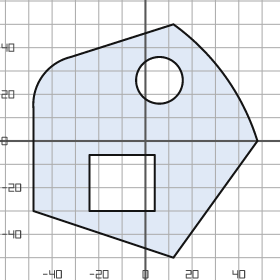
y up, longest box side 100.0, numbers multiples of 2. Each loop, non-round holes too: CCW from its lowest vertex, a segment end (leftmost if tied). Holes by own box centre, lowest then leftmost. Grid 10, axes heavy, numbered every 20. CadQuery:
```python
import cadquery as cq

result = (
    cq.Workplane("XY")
    .moveTo(12.0, -50.0)
    .lineTo(48.0, 0.0)
    .threePointArc((34.0, 28.0), (12.0, 50.0))
    .lineTo(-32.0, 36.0)
    .threePointArc((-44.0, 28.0), (-48.0, 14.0))
    .lineTo(-48.0, -30.0)
    .close()
    .moveTo(-24.0, -30.0)
    .lineTo(4.0, -30.0)
    .lineTo(4.0, -6.0)
    .lineTo(-24.0, -6.0)
    .close()
    .moveTo(6.0, 26.0)
    .circle(10.0)
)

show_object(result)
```